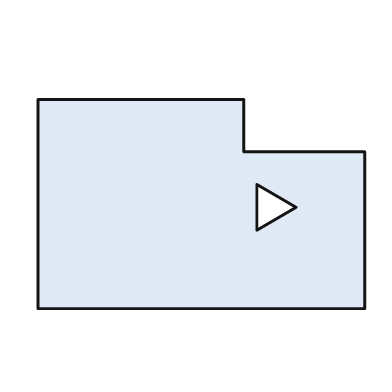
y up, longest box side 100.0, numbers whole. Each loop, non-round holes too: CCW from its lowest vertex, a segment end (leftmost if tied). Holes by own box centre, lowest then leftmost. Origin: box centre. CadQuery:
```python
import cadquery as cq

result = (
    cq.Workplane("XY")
    .moveTo(-50.0, -32.0)
    .lineTo(50.0, -32.0)
    .lineTo(50.0, 16.0)
    .lineTo(13.0, 16.0)
    .lineTo(13.0, 32.0)
    .lineTo(-50.0, 32.0)
    .close()
    .moveTo(17.0, -8.0)
    .lineTo(29.0, -1.0)
    .lineTo(17.0, 6.0)
    .close()
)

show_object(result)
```